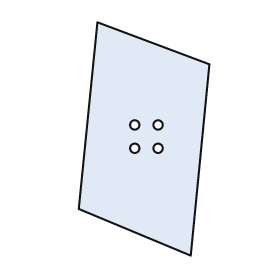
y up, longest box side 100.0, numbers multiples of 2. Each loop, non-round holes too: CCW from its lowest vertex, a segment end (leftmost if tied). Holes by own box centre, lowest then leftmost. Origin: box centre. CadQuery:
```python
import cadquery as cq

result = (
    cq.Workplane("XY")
    .moveTo(20.0, -50.0)
    .lineTo(28.0, 32.0)
    .lineTo(-20.0, 50.0)
    .lineTo(-28.0, -30.0)
    .close()
    .moveTo(-4.0, -4.0)
    .circle(2.0)
    .moveTo(6.0, -4.0)
    .circle(2.0)
    .moveTo(-4.0, 6.0)
    .circle(2.0)
    .moveTo(6.0, 6.0)
    .circle(2.0)
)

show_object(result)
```